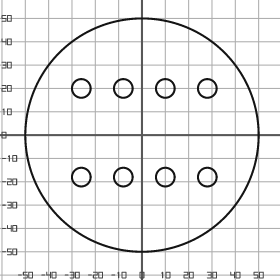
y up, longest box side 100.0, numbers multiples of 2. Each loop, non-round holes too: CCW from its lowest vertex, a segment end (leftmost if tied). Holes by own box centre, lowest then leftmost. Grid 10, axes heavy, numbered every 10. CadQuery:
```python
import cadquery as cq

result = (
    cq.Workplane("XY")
    .moveTo(0.0, 0.0)
    .circle(50.0)
    .moveTo(-26.0, -18.0)
    .circle(4.0)
    .moveTo(-8.0, -18.0)
    .circle(4.0)
    .moveTo(10.0, -18.0)
    .circle(4.0)
    .moveTo(28.0, -18.0)
    .circle(4.0)
    .moveTo(-26.0, 20.0)
    .circle(4.0)
    .moveTo(-8.0, 20.0)
    .circle(4.0)
    .moveTo(10.0, 20.0)
    .circle(4.0)
    .moveTo(28.0, 20.0)
    .circle(4.0)
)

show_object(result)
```